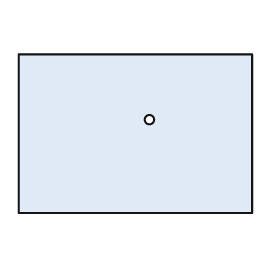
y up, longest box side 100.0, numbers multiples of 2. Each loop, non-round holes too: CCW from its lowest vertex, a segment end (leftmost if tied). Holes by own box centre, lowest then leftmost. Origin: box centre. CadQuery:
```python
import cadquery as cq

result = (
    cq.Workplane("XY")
    .moveTo(-50.0, -34.0)
    .lineTo(50.0, -34.0)
    .lineTo(50.0, 34.0)
    .lineTo(-50.0, 34.0)
    .close()
    .moveTo(6.0, 6.0)
    .circle(2.0)
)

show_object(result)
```